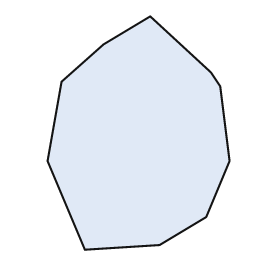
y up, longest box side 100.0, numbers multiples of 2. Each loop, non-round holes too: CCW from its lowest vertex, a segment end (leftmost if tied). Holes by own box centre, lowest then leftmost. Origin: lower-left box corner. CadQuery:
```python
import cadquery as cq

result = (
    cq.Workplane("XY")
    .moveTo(16.0, 0.0)
    .lineTo(48.0, 2.0)
    .lineTo(68.0, 14.0)
    .lineTo(78.0, 38.0)
    .lineTo(74.0, 70.0)
    .lineTo(70.0, 76.0)
    .lineTo(44.0, 100.0)
    .lineTo(24.0, 88.0)
    .lineTo(6.0, 72.0)
    .lineTo(0.0, 38.0)
    .close()
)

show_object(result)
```